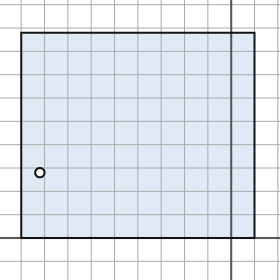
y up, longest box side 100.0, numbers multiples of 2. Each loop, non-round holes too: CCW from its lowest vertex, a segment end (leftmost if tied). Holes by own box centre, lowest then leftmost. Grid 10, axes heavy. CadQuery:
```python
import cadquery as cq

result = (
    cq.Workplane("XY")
    .moveTo(-90.0, 0.0)
    .lineTo(10.0, 0.0)
    .lineTo(10.0, 88.0)
    .lineTo(-90.0, 88.0)
    .close()
    .moveTo(-82.0, 28.0)
    .circle(2.0)
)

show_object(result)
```